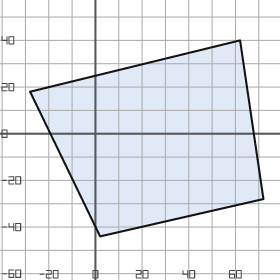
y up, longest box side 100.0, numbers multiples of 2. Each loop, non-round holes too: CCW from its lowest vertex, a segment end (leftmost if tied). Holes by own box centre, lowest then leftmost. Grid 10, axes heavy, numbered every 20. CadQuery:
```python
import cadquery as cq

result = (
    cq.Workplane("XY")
    .moveTo(2.0, -44.0)
    .lineTo(72.0, -28.0)
    .lineTo(62.0, 40.0)
    .lineTo(-28.0, 18.0)
    .close()
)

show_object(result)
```